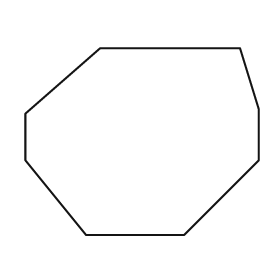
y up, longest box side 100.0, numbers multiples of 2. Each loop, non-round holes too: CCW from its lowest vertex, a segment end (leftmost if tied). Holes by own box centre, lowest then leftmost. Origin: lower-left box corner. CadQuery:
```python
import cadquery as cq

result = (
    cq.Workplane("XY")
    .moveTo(26.0, 0.0)
    .lineTo(68.0, 0.0)
    .lineTo(100.0, 32.0)
    .lineTo(100.0, 54.0)
    .lineTo(92.0, 80.0)
    .lineTo(32.0, 80.0)
    .lineTo(0.0, 52.0)
    .lineTo(0.0, 32.0)
    .close()
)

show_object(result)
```